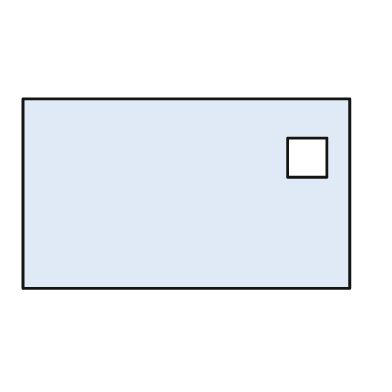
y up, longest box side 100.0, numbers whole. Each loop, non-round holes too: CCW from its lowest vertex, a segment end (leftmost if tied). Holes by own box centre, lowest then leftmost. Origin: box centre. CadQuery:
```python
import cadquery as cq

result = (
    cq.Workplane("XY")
    .moveTo(-50.0, -29.0)
    .lineTo(50.0, -29.0)
    .lineTo(50.0, 29.0)
    .lineTo(-50.0, 29.0)
    .close()
    .moveTo(31.0, 5.0)
    .lineTo(43.0, 5.0)
    .lineTo(43.0, 17.0)
    .lineTo(31.0, 17.0)
    .close()
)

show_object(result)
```